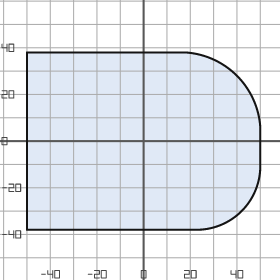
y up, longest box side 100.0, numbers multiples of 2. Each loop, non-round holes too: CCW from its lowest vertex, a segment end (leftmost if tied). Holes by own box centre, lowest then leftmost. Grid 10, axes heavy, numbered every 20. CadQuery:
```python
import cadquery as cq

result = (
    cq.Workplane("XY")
    .moveTo(-50.0, -38.0)
    .lineTo(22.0, -38.0)
    .threePointArc((42.0, -30.0), (50.0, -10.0))
    .lineTo(50.0, 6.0)
    .threePointArc((40.0, 28.0), (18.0, 38.0))
    .lineTo(-50.0, 38.0)
    .close()
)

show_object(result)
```